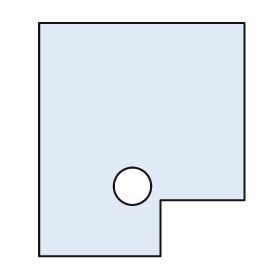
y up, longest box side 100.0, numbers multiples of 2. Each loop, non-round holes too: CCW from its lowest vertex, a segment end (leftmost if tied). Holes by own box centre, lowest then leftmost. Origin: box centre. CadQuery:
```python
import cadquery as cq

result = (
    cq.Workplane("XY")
    .moveTo(-44.0, -50.0)
    .lineTo(8.0, -50.0)
    .lineTo(8.0, -26.0)
    .lineTo(44.0, -26.0)
    .lineTo(44.0, 50.0)
    .lineTo(-44.0, 50.0)
    .close()
    .moveTo(-4.0, -20.0)
    .circle(8.0)
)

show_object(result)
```